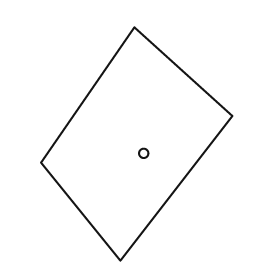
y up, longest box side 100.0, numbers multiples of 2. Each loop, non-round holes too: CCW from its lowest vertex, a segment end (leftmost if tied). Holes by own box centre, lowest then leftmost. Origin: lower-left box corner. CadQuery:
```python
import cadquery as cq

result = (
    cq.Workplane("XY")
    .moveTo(34.0, 0.0)
    .lineTo(82.0, 62.0)
    .lineTo(40.0, 100.0)
    .lineTo(0.0, 42.0)
    .close()
    .moveTo(44.0, 46.0)
    .circle(2.0)
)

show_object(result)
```